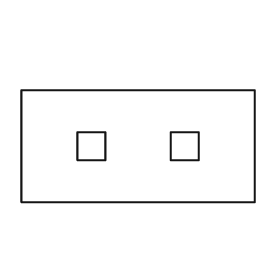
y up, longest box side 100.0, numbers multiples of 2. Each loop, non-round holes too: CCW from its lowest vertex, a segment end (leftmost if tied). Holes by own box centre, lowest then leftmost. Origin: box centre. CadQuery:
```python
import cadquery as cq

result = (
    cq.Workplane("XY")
    .moveTo(-50.0, -24.0)
    .lineTo(50.0, -24.0)
    .lineTo(50.0, 24.0)
    .lineTo(-50.0, 24.0)
    .close()
    .moveTo(-26.0, -6.0)
    .lineTo(-14.0, -6.0)
    .lineTo(-14.0, 6.0)
    .lineTo(-26.0, 6.0)
    .close()
    .moveTo(14.0, -6.0)
    .lineTo(26.0, -6.0)
    .lineTo(26.0, 6.0)
    .lineTo(14.0, 6.0)
    .close()
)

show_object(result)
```